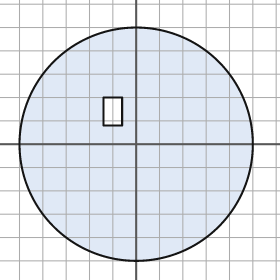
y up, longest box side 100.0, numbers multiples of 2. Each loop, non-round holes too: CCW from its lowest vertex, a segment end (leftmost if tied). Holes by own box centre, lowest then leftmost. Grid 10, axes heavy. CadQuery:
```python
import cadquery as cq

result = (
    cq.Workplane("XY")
    .moveTo(0.0, 0.0)
    .circle(50.0)
    .moveTo(-14.0, 8.0)
    .lineTo(-6.0, 8.0)
    .lineTo(-6.0, 20.0)
    .lineTo(-14.0, 20.0)
    .close()
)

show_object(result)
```